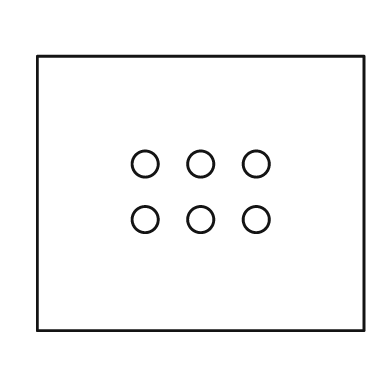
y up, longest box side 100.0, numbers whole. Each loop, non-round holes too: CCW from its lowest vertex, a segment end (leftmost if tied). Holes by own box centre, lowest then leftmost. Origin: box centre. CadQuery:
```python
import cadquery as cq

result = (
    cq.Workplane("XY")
    .moveTo(-50.0, -42.0)
    .lineTo(50.0, -42.0)
    .lineTo(50.0, 42.0)
    .lineTo(-50.0, 42.0)
    .close()
    .moveTo(-17.0, -8.0)
    .circle(4.0)
    .moveTo(0.0, -8.0)
    .circle(4.0)
    .moveTo(17.0, -8.0)
    .circle(4.0)
    .moveTo(-17.0, 9.0)
    .circle(4.0)
    .moveTo(0.0, 9.0)
    .circle(4.0)
    .moveTo(17.0, 9.0)
    .circle(4.0)
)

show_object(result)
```